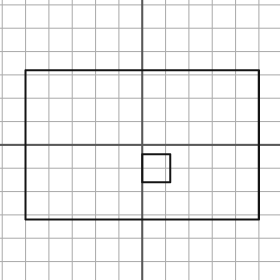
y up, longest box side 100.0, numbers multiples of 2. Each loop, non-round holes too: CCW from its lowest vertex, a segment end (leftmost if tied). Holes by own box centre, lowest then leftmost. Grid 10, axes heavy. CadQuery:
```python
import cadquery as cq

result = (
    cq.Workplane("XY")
    .moveTo(-50.0, -32.0)
    .lineTo(50.0, -32.0)
    .lineTo(50.0, 32.0)
    .lineTo(-50.0, 32.0)
    .close()
    .moveTo(0.0, -16.0)
    .lineTo(12.0, -16.0)
    .lineTo(12.0, -4.0)
    .lineTo(0.0, -4.0)
    .close()
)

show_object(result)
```